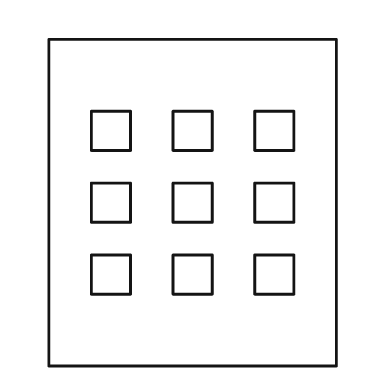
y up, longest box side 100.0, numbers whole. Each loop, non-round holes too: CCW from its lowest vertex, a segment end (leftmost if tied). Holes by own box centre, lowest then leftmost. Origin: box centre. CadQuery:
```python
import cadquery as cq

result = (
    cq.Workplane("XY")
    .moveTo(-44.0, -50.0)
    .lineTo(44.0, -50.0)
    .lineTo(44.0, 50.0)
    .lineTo(-44.0, 50.0)
    .close()
    .moveTo(-31.0, -28.0)
    .lineTo(-19.0, -28.0)
    .lineTo(-19.0, -16.0)
    .lineTo(-31.0, -16.0)
    .close()
    .moveTo(-6.0, -28.0)
    .lineTo(6.0, -28.0)
    .lineTo(6.0, -16.0)
    .lineTo(-6.0, -16.0)
    .close()
    .moveTo(19.0, -28.0)
    .lineTo(31.0, -28.0)
    .lineTo(31.0, -16.0)
    .lineTo(19.0, -16.0)
    .close()
    .moveTo(-31.0, -6.0)
    .lineTo(-19.0, -6.0)
    .lineTo(-19.0, 6.0)
    .lineTo(-31.0, 6.0)
    .close()
    .moveTo(-6.0, -6.0)
    .lineTo(6.0, -6.0)
    .lineTo(6.0, 6.0)
    .lineTo(-6.0, 6.0)
    .close()
    .moveTo(19.0, -6.0)
    .lineTo(31.0, -6.0)
    .lineTo(31.0, 6.0)
    .lineTo(19.0, 6.0)
    .close()
    .moveTo(-31.0, 16.0)
    .lineTo(-19.0, 16.0)
    .lineTo(-19.0, 28.0)
    .lineTo(-31.0, 28.0)
    .close()
    .moveTo(-6.0, 16.0)
    .lineTo(6.0, 16.0)
    .lineTo(6.0, 28.0)
    .lineTo(-6.0, 28.0)
    .close()
    .moveTo(19.0, 16.0)
    .lineTo(31.0, 16.0)
    .lineTo(31.0, 28.0)
    .lineTo(19.0, 28.0)
    .close()
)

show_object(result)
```